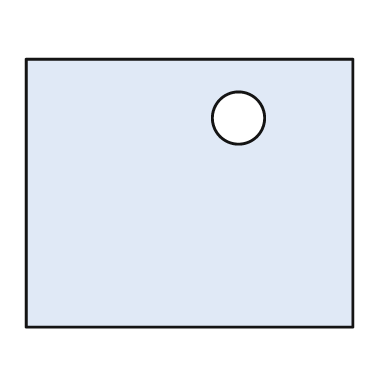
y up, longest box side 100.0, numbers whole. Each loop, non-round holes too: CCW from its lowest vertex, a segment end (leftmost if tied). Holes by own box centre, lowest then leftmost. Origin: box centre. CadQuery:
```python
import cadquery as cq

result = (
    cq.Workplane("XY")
    .moveTo(-50.0, -41.0)
    .lineTo(50.0, -41.0)
    .lineTo(50.0, 41.0)
    .lineTo(-50.0, 41.0)
    .close()
    .moveTo(15.0, 23.0)
    .circle(8.0)
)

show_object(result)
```